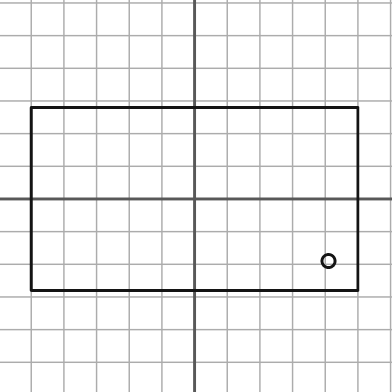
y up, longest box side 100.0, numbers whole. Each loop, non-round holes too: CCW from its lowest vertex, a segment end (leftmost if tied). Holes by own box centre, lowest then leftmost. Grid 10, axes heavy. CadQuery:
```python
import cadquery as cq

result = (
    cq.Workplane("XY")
    .moveTo(-50.0, -28.0)
    .lineTo(50.0, -28.0)
    .lineTo(50.0, 28.0)
    .lineTo(-50.0, 28.0)
    .close()
    .moveTo(41.0, -19.0)
    .circle(2.0)
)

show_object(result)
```